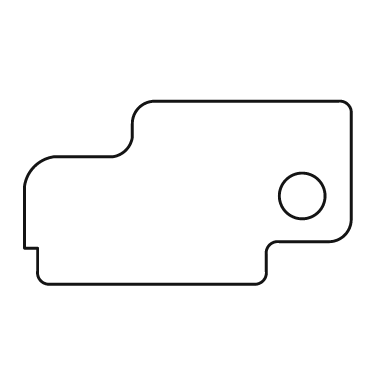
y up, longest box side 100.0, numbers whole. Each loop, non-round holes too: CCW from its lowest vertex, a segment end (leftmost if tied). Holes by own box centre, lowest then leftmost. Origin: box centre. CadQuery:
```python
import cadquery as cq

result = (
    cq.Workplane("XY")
    .moveTo(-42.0, -28.0)
    .lineTo(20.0, -28.0)
    .threePointArc((23.0, -27.0), (24.0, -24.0))
    .lineTo(24.0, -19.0)
    .threePointArc((25.0, -16.0), (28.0, -15.0))
    .lineTo(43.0, -15.0)
    .threePointArc((48.0, -13.0), (50.0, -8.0))
    .lineTo(50.0, 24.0)
    .threePointArc((49.0, 27.0), (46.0, 28.0))
    .lineTo(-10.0, 28.0)
    .threePointArc((-15.0, 26.0), (-17.0, 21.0))
    .lineTo(-17.0, 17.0)
    .threePointArc((-19.0, 13.0), (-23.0, 11.0))
    .lineTo(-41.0, 11.0)
    .threePointArc((-47.0, 8.0), (-50.0, 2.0))
    .lineTo(-50.0, -17.0)
    .lineTo(-46.0, -17.0)
    .lineTo(-46.0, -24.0)
    .threePointArc((-45.0, -27.0), (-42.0, -28.0))
    .close()
    .moveTo(35.0, -1.0)
    .circle(7.0)
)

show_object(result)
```